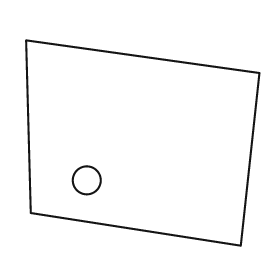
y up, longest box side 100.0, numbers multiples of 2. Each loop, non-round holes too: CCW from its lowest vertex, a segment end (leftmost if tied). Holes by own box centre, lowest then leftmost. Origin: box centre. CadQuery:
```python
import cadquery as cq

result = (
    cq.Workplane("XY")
    .moveTo(42.0, -44.0)
    .lineTo(50.0, 30.0)
    .lineTo(-50.0, 44.0)
    .lineTo(-48.0, -30.0)
    .close()
    .moveTo(-24.0, -16.0)
    .circle(6.0)
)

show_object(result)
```